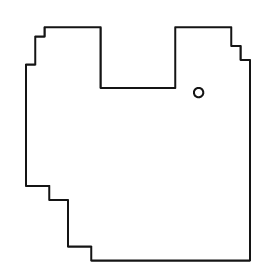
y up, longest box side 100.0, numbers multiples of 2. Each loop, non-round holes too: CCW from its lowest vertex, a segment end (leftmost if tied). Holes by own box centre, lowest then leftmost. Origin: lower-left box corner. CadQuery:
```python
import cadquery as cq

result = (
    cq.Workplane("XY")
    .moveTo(28.0, 0.0)
    .lineTo(96.0, 0.0)
    .lineTo(96.0, 86.0)
    .lineTo(92.0, 86.0)
    .lineTo(92.0, 92.0)
    .lineTo(88.0, 92.0)
    .lineTo(88.0, 100.0)
    .lineTo(64.0, 100.0)
    .lineTo(64.0, 74.0)
    .lineTo(32.0, 74.0)
    .lineTo(32.0, 100.0)
    .lineTo(8.0, 100.0)
    .lineTo(8.0, 96.0)
    .lineTo(4.0, 96.0)
    .lineTo(4.0, 84.0)
    .lineTo(0.0, 84.0)
    .lineTo(0.0, 32.0)
    .lineTo(10.0, 32.0)
    .lineTo(10.0, 26.0)
    .lineTo(18.0, 26.0)
    .lineTo(18.0, 6.0)
    .lineTo(28.0, 6.0)
    .close()
    .moveTo(74.0, 72.0)
    .circle(2.0)
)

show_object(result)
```